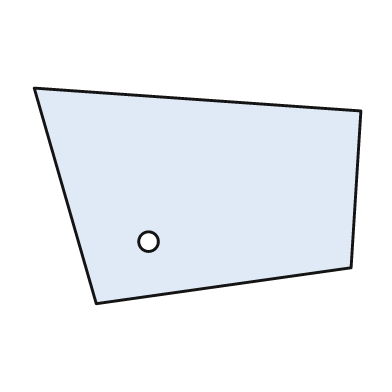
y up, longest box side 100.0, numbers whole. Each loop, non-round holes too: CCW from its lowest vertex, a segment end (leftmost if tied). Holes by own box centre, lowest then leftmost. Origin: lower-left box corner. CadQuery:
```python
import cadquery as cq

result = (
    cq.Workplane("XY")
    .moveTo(19.0, 0.0)
    .lineTo(97.0, 11.0)
    .lineTo(100.0, 59.0)
    .lineTo(0.0, 66.0)
    .close()
    .moveTo(35.0, 19.0)
    .circle(3.0)
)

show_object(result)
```